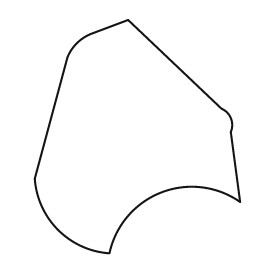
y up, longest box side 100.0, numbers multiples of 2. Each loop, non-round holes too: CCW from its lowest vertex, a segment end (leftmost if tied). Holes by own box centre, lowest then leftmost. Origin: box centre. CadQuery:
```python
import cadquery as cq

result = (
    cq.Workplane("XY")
    .moveTo(-12.0, -50.0)
    .threePointArc((10.0, -24.0), (44.0, -28.0))
    .lineTo(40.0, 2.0)
    .threePointArc((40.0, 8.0), (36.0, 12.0))
    .lineTo(-4.0, 50.0)
    .lineTo(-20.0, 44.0)
    .threePointArc((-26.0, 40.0), (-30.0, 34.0))
    .lineTo(-44.0, -18.0)
    .threePointArc((-34.0, -40.0), (-12.0, -50.0))
    .close()
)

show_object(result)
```